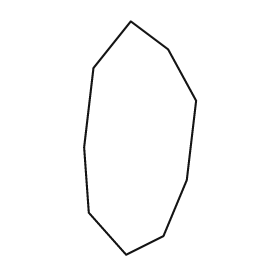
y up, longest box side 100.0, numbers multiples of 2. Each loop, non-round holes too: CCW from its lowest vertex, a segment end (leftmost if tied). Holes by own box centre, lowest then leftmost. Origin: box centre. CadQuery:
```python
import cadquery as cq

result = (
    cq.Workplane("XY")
    .moveTo(-6.0, -50.0)
    .lineTo(10.0, -42.0)
    .lineTo(20.0, -18.0)
    .lineTo(24.0, 16.0)
    .lineTo(12.0, 38.0)
    .lineTo(-4.0, 50.0)
    .lineTo(-20.0, 30.0)
    .lineTo(-24.0, -4.0)
    .lineTo(-22.0, -32.0)
    .close()
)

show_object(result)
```